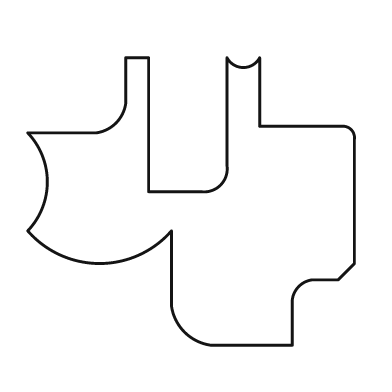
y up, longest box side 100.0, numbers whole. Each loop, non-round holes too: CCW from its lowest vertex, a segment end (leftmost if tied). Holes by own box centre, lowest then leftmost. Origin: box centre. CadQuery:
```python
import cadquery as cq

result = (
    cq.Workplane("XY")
    .moveTo(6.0, -44.0)
    .lineTo(31.0, -44.0)
    .lineTo(31.0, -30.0)
    .threePointArc((33.0, -26.0), (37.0, -24.0))
    .lineTo(45.0, -24.0)
    .lineTo(50.0, -19.0)
    .lineTo(50.0, 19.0)
    .threePointArc((49.0, 22.0), (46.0, 23.0))
    .lineTo(21.0, 23.0)
    .lineTo(21.0, 44.0)
    .threePointArc((16.0, 41.0), (11.0, 44.0))
    .lineTo(11.0, 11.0)
    .threePointArc((9.0, 5.0), (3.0, 3.0))
    .lineTo(-13.0, 3.0)
    .lineTo(-13.0, 44.0)
    .lineTo(-20.0, 44.0)
    .lineTo(-20.0, 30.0)
    .threePointArc((-23.0, 24.0), (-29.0, 21.0))
    .lineTo(-50.0, 21.0)
    .threePointArc((-44.0, 6.0), (-50.0, -9.0))
    .threePointArc((-28.0, -19.0), (-6.0, -9.0))
    .lineTo(-6.0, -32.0)
    .threePointArc((-2.0, -40.0), (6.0, -44.0))
    .close()
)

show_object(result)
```